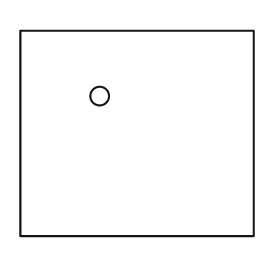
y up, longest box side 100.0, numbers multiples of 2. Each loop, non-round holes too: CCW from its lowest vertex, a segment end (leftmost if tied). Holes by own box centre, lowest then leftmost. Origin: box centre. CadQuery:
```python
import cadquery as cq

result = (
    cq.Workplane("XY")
    .moveTo(-50.0, -44.0)
    .lineTo(50.0, -44.0)
    .lineTo(50.0, 44.0)
    .lineTo(-50.0, 44.0)
    .close()
    .moveTo(-16.0, 16.0)
    .circle(4.0)
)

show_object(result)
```